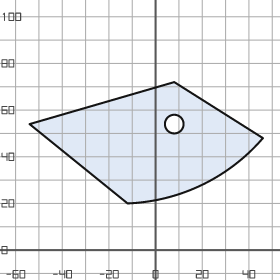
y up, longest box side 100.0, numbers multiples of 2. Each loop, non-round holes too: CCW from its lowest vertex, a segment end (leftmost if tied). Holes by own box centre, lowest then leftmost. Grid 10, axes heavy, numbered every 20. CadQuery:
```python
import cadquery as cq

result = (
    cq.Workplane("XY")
    .moveTo(-12.0, 20.0)
    .threePointArc((20.0, 28.0), (46.0, 48.0))
    .lineTo(8.0, 72.0)
    .lineTo(-54.0, 54.0)
    .close()
    .moveTo(8.0, 54.0)
    .circle(4.0)
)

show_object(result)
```